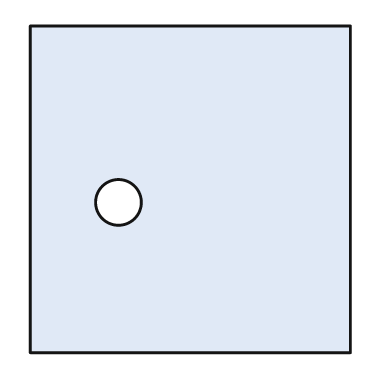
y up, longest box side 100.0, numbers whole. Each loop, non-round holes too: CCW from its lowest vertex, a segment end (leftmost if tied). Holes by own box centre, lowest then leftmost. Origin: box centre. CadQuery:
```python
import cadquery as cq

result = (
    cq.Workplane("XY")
    .moveTo(-49.0, -50.0)
    .lineTo(49.0, -50.0)
    .lineTo(49.0, 50.0)
    .lineTo(-49.0, 50.0)
    .close()
    .moveTo(-22.0, -4.0)
    .circle(7.0)
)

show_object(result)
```